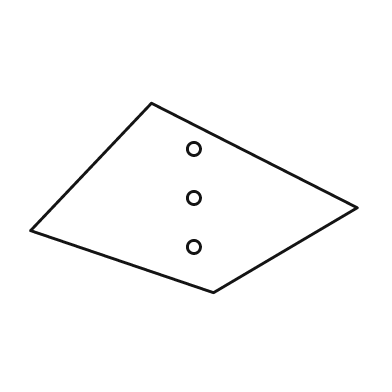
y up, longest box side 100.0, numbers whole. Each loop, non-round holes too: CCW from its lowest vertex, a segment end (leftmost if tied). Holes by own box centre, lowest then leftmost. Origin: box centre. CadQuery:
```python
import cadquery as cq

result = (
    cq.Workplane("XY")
    .moveTo(6.0, -29.0)
    .lineTo(50.0, -3.0)
    .lineTo(-13.0, 29.0)
    .lineTo(-50.0, -10.0)
    .close()
    .moveTo(0.0, -15.0)
    .circle(2.0)
    .moveTo(0.0, 0.0)
    .circle(2.0)
    .moveTo(0.0, 15.0)
    .circle(2.0)
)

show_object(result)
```